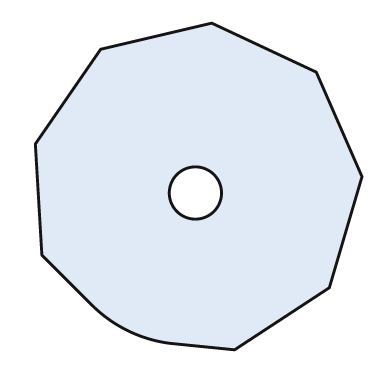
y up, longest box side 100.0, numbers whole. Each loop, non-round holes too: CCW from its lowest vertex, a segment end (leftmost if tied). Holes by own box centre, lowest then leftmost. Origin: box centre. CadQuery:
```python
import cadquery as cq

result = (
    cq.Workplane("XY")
    .moveTo(11.0, -50.0)
    .lineTo(40.0, -31.0)
    .lineTo(50.0, 3.0)
    .lineTo(36.0, 35.0)
    .lineTo(4.0, 50.0)
    .lineTo(-30.0, 42.0)
    .lineTo(-50.0, 13.0)
    .lineTo(-48.0, -21.0)
    .lineTo(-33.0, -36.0)
    .threePointArc((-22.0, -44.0), (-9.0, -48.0))
    .close()
    .moveTo(-1.0, -2.0)
    .circle(8.0)
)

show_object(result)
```